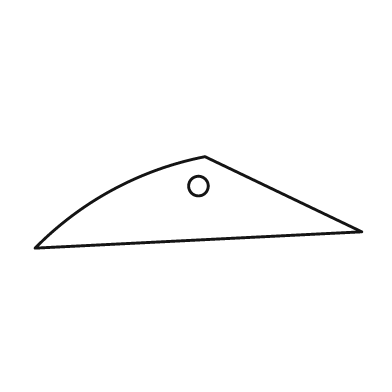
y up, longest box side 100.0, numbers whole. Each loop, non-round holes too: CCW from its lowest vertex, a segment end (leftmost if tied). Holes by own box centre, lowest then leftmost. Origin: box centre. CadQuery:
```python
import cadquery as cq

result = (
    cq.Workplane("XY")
    .moveTo(-50.0, -14.0)
    .lineTo(50.0, -9.0)
    .lineTo(2.0, 14.0)
    .threePointArc((-26.0, 4.0), (-50.0, -14.0))
    .close()
    .moveTo(0.0, 5.0)
    .circle(3.0)
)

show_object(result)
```